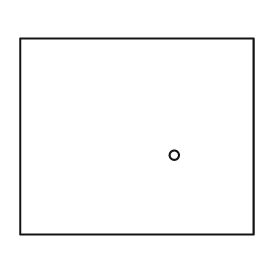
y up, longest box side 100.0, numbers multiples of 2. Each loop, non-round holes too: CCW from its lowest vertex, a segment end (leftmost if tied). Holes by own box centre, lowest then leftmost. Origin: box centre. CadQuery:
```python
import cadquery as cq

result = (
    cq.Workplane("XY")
    .moveTo(-50.0, -42.0)
    .lineTo(50.0, -42.0)
    .lineTo(50.0, 42.0)
    .lineTo(-50.0, 42.0)
    .close()
    .moveTo(16.0, -8.0)
    .circle(2.0)
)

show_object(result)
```